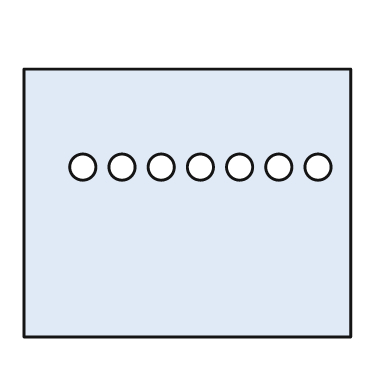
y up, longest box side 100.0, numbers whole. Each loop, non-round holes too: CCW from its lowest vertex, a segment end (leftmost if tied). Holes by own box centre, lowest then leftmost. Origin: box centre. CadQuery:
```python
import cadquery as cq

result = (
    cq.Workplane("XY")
    .moveTo(-50.0, -41.0)
    .lineTo(50.0, -41.0)
    .lineTo(50.0, 41.0)
    .lineTo(-50.0, 41.0)
    .close()
    .moveTo(-32.0, 11.0)
    .circle(4.0)
    .moveTo(-20.0, 11.0)
    .circle(4.0)
    .moveTo(-8.0, 11.0)
    .circle(4.0)
    .moveTo(4.0, 11.0)
    .circle(4.0)
    .moveTo(16.0, 11.0)
    .circle(4.0)
    .moveTo(28.0, 11.0)
    .circle(4.0)
    .moveTo(40.0, 11.0)
    .circle(4.0)
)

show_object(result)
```